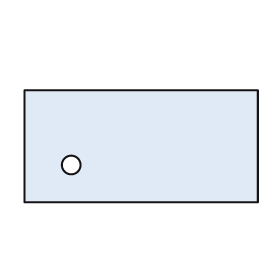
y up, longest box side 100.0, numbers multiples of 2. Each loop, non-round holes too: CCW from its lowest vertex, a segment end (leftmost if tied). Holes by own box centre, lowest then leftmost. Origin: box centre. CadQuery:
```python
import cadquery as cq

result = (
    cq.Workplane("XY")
    .moveTo(-50.0, -24.0)
    .lineTo(50.0, -24.0)
    .lineTo(50.0, 24.0)
    .lineTo(-50.0, 24.0)
    .close()
    .moveTo(-30.0, -8.0)
    .circle(4.0)
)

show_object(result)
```